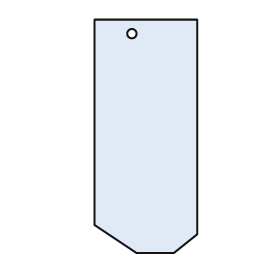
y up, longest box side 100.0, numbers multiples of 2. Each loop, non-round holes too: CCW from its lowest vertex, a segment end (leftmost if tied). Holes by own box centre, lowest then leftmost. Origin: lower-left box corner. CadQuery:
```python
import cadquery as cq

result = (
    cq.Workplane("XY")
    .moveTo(18.0, 0.0)
    .lineTo(34.0, 0.0)
    .lineTo(44.0, 8.0)
    .lineTo(44.0, 100.0)
    .lineTo(0.0, 100.0)
    .lineTo(0.0, 12.0)
    .close()
    .moveTo(16.0, 94.0)
    .circle(2.0)
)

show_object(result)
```